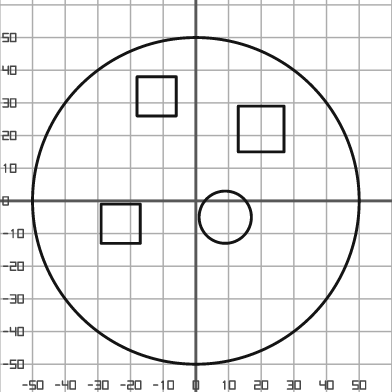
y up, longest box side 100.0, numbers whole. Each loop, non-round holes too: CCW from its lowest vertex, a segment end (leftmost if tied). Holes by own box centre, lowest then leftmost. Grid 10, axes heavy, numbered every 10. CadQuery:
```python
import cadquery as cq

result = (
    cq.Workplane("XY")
    .moveTo(0.0, 0.0)
    .circle(50.0)
    .moveTo(-29.0, -13.0)
    .lineTo(-17.0, -13.0)
    .lineTo(-17.0, -1.0)
    .lineTo(-29.0, -1.0)
    .close()
    .moveTo(9.0, -5.0)
    .circle(8.0)
    .moveTo(13.0, 15.0)
    .lineTo(27.0, 15.0)
    .lineTo(27.0, 29.0)
    .lineTo(13.0, 29.0)
    .close()
    .moveTo(-18.0, 26.0)
    .lineTo(-6.0, 26.0)
    .lineTo(-6.0, 38.0)
    .lineTo(-18.0, 38.0)
    .close()
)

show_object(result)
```